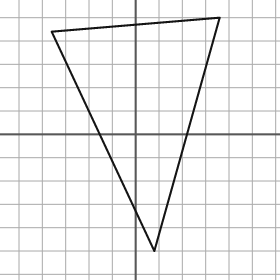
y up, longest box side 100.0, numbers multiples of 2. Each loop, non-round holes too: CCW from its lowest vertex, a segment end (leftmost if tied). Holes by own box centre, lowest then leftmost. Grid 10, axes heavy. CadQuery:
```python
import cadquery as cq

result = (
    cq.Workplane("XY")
    .moveTo(8.0, -50.0)
    .lineTo(36.0, 50.0)
    .lineTo(-36.0, 44.0)
    .close()
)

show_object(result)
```